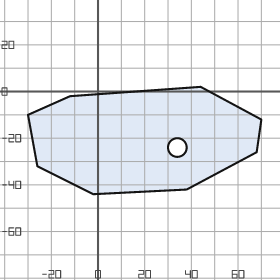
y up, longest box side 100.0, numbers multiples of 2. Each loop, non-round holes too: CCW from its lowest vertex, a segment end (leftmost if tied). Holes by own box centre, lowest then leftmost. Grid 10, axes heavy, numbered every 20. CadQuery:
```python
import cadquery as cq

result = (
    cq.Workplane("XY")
    .moveTo(-2.0, -44.0)
    .lineTo(38.0, -42.0)
    .lineTo(68.0, -26.0)
    .lineTo(70.0, -12.0)
    .lineTo(44.0, 2.0)
    .lineTo(-12.0, -2.0)
    .lineTo(-30.0, -10.0)
    .lineTo(-26.0, -32.0)
    .close()
    .moveTo(34.0, -24.0)
    .circle(4.0)
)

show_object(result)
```